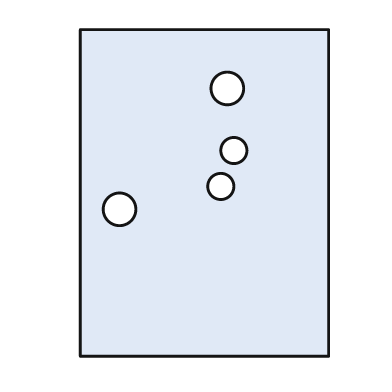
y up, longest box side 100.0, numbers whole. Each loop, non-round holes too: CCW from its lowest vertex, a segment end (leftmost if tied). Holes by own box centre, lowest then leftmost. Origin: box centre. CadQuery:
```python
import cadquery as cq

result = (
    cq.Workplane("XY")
    .moveTo(-38.0, -50.0)
    .lineTo(38.0, -50.0)
    .lineTo(38.0, 50.0)
    .lineTo(-38.0, 50.0)
    .close()
    .moveTo(-26.0, -5.0)
    .circle(5.0)
    .moveTo(5.0, 2.0)
    .circle(4.0)
    .moveTo(9.0, 13.0)
    .circle(4.0)
    .moveTo(7.0, 32.0)
    .circle(5.0)
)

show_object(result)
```